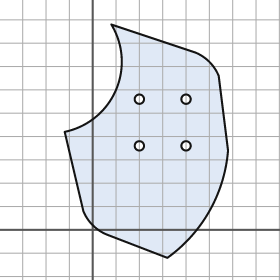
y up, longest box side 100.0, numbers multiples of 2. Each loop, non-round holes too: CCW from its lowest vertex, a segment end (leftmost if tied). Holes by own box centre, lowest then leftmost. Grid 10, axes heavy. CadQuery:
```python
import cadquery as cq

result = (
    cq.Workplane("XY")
    .moveTo(32.0, -12.0)
    .threePointArc((50.0, 8.0), (58.0, 34.0))
    .lineTo(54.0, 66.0)
    .threePointArc((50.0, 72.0), (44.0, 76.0))
    .lineTo(8.0, 88.0)
    .threePointArc((10.0, 60.0), (-12.0, 42.0))
    .lineTo(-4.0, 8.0)
    .threePointArc((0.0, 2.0), (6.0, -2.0))
    .close()
    .moveTo(20.0, 36.0)
    .circle(2.0)
    .moveTo(40.0, 36.0)
    .circle(2.0)
    .moveTo(20.0, 56.0)
    .circle(2.0)
    .moveTo(40.0, 56.0)
    .circle(2.0)
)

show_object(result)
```